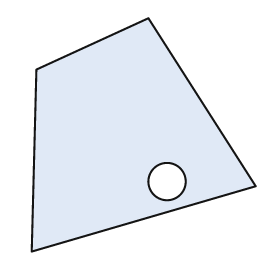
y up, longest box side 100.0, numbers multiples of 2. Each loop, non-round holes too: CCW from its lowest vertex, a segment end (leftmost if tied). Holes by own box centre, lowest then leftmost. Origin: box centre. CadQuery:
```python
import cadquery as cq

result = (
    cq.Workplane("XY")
    .moveTo(-48.0, -50.0)
    .lineTo(48.0, -22.0)
    .lineTo(2.0, 50.0)
    .lineTo(-46.0, 28.0)
    .close()
    .moveTo(10.0, -20.0)
    .circle(8.0)
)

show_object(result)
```